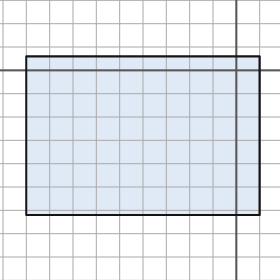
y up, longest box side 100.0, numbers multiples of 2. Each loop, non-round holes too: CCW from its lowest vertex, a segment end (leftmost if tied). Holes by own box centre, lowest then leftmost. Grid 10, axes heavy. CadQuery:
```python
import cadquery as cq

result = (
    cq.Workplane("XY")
    .moveTo(-90.0, -62.0)
    .lineTo(10.0, -62.0)
    .lineTo(10.0, 6.0)
    .lineTo(-90.0, 6.0)
    .close()
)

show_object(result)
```